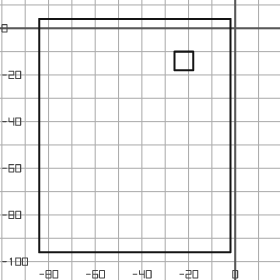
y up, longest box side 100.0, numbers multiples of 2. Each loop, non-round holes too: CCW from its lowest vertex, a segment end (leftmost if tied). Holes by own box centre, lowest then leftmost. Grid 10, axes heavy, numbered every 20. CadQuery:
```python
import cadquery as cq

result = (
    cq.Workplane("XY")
    .moveTo(-84.0, -96.0)
    .lineTo(-2.0, -96.0)
    .lineTo(-2.0, 4.0)
    .lineTo(-84.0, 4.0)
    .close()
    .moveTo(-26.0, -18.0)
    .lineTo(-18.0, -18.0)
    .lineTo(-18.0, -10.0)
    .lineTo(-26.0, -10.0)
    .close()
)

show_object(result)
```